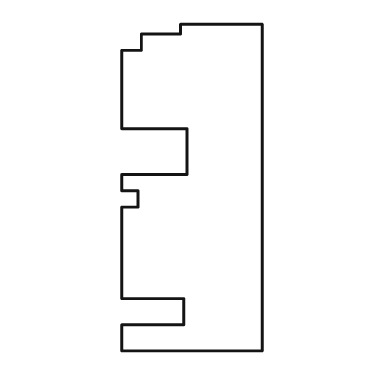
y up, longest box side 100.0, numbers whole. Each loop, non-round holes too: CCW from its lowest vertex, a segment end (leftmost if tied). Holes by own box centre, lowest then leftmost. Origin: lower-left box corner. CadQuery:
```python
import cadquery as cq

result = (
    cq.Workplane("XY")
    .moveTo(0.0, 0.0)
    .lineTo(43.0, 0.0)
    .lineTo(43.0, 100.0)
    .lineTo(18.0, 100.0)
    .lineTo(18.0, 97.0)
    .lineTo(6.0, 97.0)
    .lineTo(6.0, 92.0)
    .lineTo(0.0, 92.0)
    .lineTo(0.0, 68.0)
    .lineTo(20.0, 68.0)
    .lineTo(20.0, 54.0)
    .lineTo(0.0, 54.0)
    .lineTo(0.0, 49.0)
    .lineTo(5.0, 49.0)
    .lineTo(5.0, 44.0)
    .lineTo(0.0, 44.0)
    .lineTo(0.0, 16.0)
    .lineTo(19.0, 16.0)
    .lineTo(19.0, 8.0)
    .lineTo(0.0, 8.0)
    .close()
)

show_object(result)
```